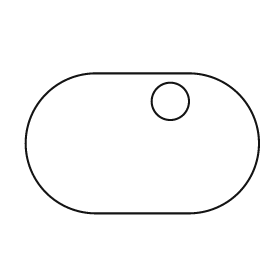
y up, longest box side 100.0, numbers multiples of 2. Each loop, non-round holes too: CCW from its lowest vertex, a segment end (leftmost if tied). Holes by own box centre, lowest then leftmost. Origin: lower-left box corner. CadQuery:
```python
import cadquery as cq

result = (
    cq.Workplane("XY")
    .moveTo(30.0, 0.0)
    .lineTo(70.0, 0.0)
    .threePointArc((100.0, 30.0), (70.0, 60.0))
    .lineTo(30.0, 60.0)
    .threePointArc((0.0, 30.0), (30.0, 0.0))
    .close()
    .moveTo(62.0, 48.0)
    .circle(8.0)
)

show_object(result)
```